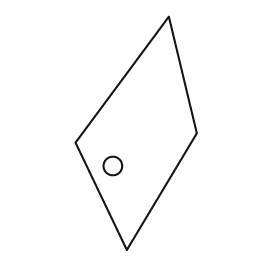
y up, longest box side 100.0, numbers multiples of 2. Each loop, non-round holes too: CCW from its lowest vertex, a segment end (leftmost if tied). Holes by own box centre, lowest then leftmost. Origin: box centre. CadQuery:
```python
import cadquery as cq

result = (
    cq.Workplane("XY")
    .moveTo(-4.0, -50.0)
    .lineTo(26.0, 0.0)
    .lineTo(14.0, 50.0)
    .lineTo(-26.0, -4.0)
    .close()
    .moveTo(-10.0, -14.0)
    .circle(4.0)
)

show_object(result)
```